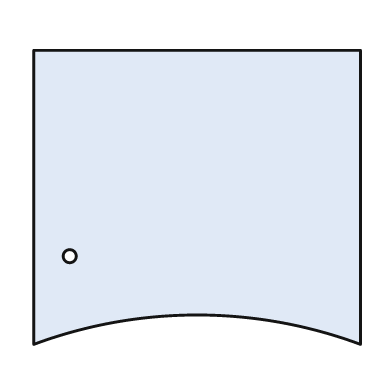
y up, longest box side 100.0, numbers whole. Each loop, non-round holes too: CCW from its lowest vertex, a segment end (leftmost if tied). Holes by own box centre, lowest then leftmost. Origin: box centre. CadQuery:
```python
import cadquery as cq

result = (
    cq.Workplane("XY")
    .moveTo(-50.0, -45.0)
    .threePointArc((0.0, -36.0), (50.0, -45.0))
    .lineTo(50.0, 45.0)
    .lineTo(-50.0, 45.0)
    .close()
    .moveTo(-39.0, -18.0)
    .circle(2.0)
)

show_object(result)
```